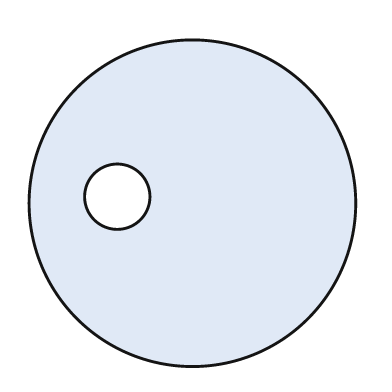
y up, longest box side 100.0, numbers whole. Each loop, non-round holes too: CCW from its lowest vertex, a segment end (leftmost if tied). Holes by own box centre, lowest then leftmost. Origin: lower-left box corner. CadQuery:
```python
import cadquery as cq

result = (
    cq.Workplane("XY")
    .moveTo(50.0, 50.0)
    .circle(50.0)
    .moveTo(27.0, 52.0)
    .circle(10.0)
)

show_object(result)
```